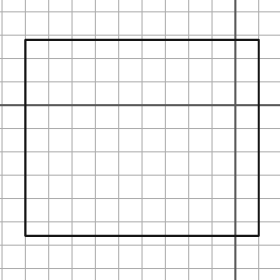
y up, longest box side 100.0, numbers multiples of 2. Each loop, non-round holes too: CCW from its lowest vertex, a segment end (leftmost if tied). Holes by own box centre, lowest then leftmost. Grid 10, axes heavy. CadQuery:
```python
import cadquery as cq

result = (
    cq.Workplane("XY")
    .moveTo(-90.0, -56.0)
    .lineTo(10.0, -56.0)
    .lineTo(10.0, 28.0)
    .lineTo(-90.0, 28.0)
    .close()
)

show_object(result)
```